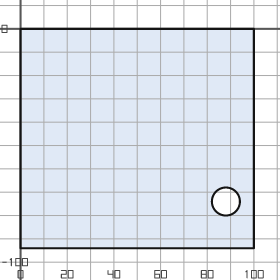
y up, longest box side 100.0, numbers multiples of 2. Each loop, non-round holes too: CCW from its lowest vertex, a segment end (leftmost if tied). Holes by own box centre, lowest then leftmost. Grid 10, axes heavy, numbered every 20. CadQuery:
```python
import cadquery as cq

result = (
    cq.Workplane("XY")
    .moveTo(0.0, -94.0)
    .lineTo(100.0, -94.0)
    .lineTo(100.0, 0.0)
    .lineTo(0.0, 0.0)
    .close()
    .moveTo(88.0, -74.0)
    .circle(6.0)
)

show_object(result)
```